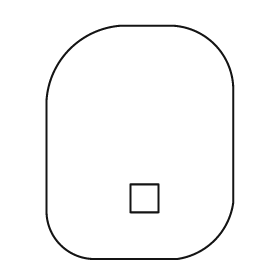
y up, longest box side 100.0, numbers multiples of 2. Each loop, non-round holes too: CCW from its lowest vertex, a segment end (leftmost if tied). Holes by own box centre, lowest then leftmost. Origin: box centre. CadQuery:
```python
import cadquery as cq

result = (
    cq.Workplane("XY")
    .moveTo(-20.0, -50.0)
    .lineTo(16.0, -50.0)
    .threePointArc((32.0, -42.0), (40.0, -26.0))
    .lineTo(40.0, 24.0)
    .threePointArc((32.0, 42.0), (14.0, 50.0))
    .lineTo(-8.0, 50.0)
    .threePointArc((-30.0, 40.0), (-40.0, 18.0))
    .lineTo(-40.0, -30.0)
    .threePointArc((-34.0, -44.0), (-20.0, -50.0))
    .close()
    .moveTo(-4.0, -30.0)
    .lineTo(8.0, -30.0)
    .lineTo(8.0, -18.0)
    .lineTo(-4.0, -18.0)
    .close()
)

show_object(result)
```